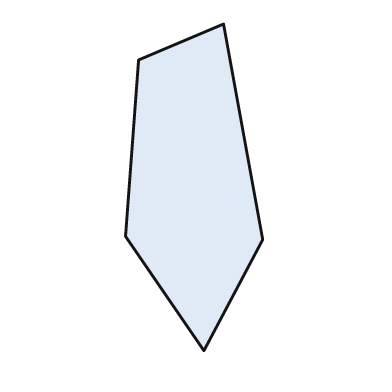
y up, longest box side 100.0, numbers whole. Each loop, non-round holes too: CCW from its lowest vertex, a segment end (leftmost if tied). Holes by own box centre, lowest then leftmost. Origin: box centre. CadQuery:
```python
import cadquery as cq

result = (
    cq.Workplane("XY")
    .moveTo(3.0, -50.0)
    .lineTo(21.0, -16.0)
    .lineTo(9.0, 50.0)
    .lineTo(-17.0, 39.0)
    .lineTo(-21.0, -15.0)
    .close()
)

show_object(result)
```